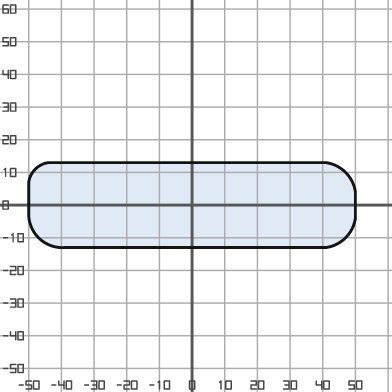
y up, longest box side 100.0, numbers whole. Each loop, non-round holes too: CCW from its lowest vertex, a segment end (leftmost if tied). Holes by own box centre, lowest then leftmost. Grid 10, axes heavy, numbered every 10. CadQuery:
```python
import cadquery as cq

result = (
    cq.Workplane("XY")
    .moveTo(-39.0, -13.0)
    .lineTo(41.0, -13.0)
    .threePointArc((47.0, -10.0), (50.0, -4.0))
    .lineTo(50.0, 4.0)
    .threePointArc((47.0, 10.0), (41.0, 13.0))
    .lineTo(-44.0, 13.0)
    .threePointArc((-48.0, 11.0), (-50.0, 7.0))
    .lineTo(-50.0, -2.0)
    .threePointArc((-47.0, -10.0), (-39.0, -13.0))
    .close()
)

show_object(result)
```